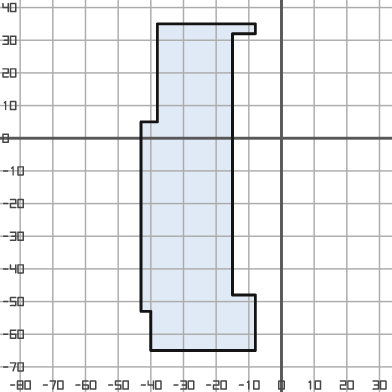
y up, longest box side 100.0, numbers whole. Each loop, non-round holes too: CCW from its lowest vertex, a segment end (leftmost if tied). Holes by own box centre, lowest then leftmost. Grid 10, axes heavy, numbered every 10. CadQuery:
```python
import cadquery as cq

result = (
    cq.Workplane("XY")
    .moveTo(-40.0, -65.0)
    .lineTo(-8.0, -65.0)
    .lineTo(-8.0, -48.0)
    .lineTo(-15.0, -48.0)
    .lineTo(-15.0, 32.0)
    .lineTo(-8.0, 32.0)
    .lineTo(-8.0, 35.0)
    .lineTo(-38.0, 35.0)
    .lineTo(-38.0, 5.0)
    .lineTo(-43.0, 5.0)
    .lineTo(-43.0, -53.0)
    .lineTo(-40.0, -53.0)
    .close()
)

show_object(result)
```